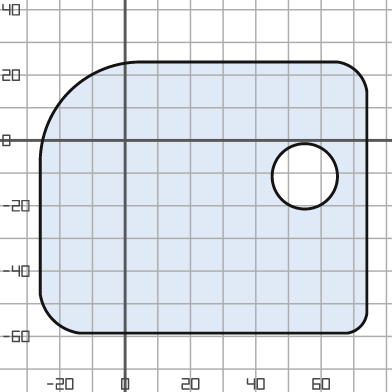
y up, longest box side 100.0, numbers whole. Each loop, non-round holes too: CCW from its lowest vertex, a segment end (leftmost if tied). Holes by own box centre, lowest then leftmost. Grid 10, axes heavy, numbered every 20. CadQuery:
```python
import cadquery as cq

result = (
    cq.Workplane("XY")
    .moveTo(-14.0, -59.0)
    .lineTo(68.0, -59.0)
    .threePointArc((72.0, -57.0), (74.0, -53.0))
    .lineTo(74.0, 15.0)
    .threePointArc((71.0, 21.0), (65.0, 24.0))
    .lineTo(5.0, 24.0)
    .threePointArc((-17.0, 15.0), (-26.0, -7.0))
    .lineTo(-26.0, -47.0)
    .threePointArc((-22.0, -55.0), (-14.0, -59.0))
    .close()
    .moveTo(55.0, -11.0)
    .circle(10.0)
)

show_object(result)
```